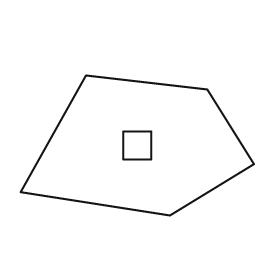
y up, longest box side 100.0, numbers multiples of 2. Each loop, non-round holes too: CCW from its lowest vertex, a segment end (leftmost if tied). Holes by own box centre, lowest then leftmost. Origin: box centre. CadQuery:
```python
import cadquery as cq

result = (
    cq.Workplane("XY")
    .moveTo(14.0, -30.0)
    .lineTo(50.0, -8.0)
    .lineTo(30.0, 24.0)
    .lineTo(-22.0, 30.0)
    .lineTo(-50.0, -20.0)
    .close()
    .moveTo(-6.0, -6.0)
    .lineTo(6.0, -6.0)
    .lineTo(6.0, 6.0)
    .lineTo(-6.0, 6.0)
    .close()
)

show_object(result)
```